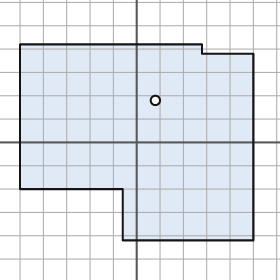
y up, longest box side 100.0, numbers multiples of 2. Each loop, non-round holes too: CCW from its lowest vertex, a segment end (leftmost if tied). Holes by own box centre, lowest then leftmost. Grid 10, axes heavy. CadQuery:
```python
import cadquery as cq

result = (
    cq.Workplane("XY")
    .moveTo(-6.0, -42.0)
    .lineTo(50.0, -42.0)
    .lineTo(50.0, 38.0)
    .lineTo(28.0, 38.0)
    .lineTo(28.0, 42.0)
    .lineTo(-50.0, 42.0)
    .lineTo(-50.0, -20.0)
    .lineTo(-6.0, -20.0)
    .close()
    .moveTo(8.0, 18.0)
    .circle(2.0)
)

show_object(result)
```